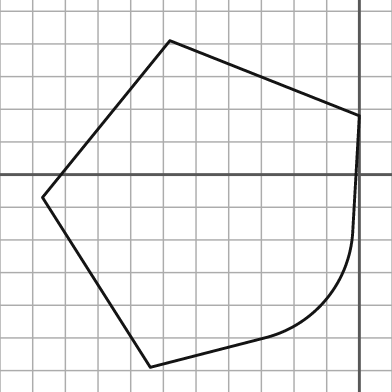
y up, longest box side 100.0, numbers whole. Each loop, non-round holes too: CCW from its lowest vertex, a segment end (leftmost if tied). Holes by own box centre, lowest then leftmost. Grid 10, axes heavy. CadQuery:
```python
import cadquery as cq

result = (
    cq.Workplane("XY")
    .moveTo(-64.0, -59.0)
    .lineTo(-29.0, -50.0)
    .threePointArc((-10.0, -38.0), (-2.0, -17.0))
    .lineTo(0.0, 18.0)
    .lineTo(-58.0, 41.0)
    .lineTo(-97.0, -7.0)
    .close()
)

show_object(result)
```